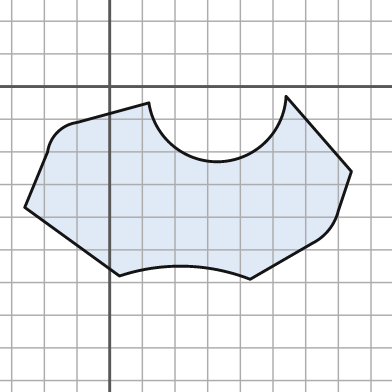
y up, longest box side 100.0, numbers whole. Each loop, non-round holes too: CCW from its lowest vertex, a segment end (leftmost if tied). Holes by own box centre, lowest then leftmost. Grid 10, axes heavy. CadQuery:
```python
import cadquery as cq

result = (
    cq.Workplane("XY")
    .moveTo(43.0, -59.0)
    .lineTo(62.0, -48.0)
    .threePointArc((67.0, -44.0), (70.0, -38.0))
    .lineTo(74.0, -26.0)
    .lineTo(54.0, -3.0)
    .threePointArc((34.0, -23.0), (12.0, -5.0))
    .lineTo(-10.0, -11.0)
    .threePointArc((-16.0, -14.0), (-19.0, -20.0))
    .lineTo(-26.0, -37.0)
    .lineTo(3.0, -58.0)
    .threePointArc((23.0, -55.0), (43.0, -59.0))
    .close()
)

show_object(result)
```